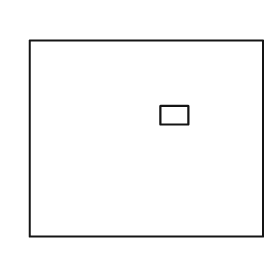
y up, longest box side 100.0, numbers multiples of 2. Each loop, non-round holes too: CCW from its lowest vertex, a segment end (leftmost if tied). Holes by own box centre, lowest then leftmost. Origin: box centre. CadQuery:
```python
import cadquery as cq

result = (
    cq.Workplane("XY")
    .moveTo(-50.0, -42.0)
    .lineTo(50.0, -42.0)
    .lineTo(50.0, 42.0)
    .lineTo(-50.0, 42.0)
    .close()
    .moveTo(6.0, 6.0)
    .lineTo(18.0, 6.0)
    .lineTo(18.0, 14.0)
    .lineTo(6.0, 14.0)
    .close()
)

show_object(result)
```